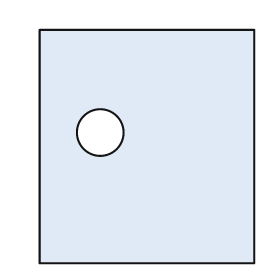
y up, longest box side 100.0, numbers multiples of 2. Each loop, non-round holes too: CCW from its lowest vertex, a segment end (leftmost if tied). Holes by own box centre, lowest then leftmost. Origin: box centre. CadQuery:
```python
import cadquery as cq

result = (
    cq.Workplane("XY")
    .moveTo(-46.0, -50.0)
    .lineTo(46.0, -50.0)
    .lineTo(46.0, 50.0)
    .lineTo(-46.0, 50.0)
    .close()
    .moveTo(-20.0, 6.0)
    .circle(10.0)
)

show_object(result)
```